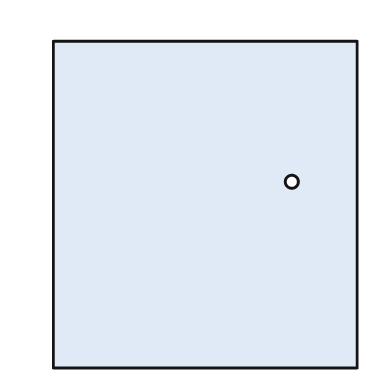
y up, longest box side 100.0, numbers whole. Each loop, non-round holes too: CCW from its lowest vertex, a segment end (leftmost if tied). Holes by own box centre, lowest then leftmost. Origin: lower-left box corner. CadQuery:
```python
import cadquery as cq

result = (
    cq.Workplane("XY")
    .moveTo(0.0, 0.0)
    .lineTo(93.0, 0.0)
    .lineTo(93.0, 100.0)
    .lineTo(0.0, 100.0)
    .close()
    .moveTo(73.0, 57.0)
    .circle(2.0)
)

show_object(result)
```